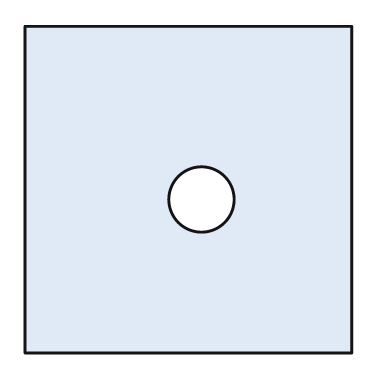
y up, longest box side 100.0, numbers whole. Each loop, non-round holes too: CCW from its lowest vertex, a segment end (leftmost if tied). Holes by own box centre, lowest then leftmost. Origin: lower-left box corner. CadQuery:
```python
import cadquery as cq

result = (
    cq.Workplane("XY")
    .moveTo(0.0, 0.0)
    .lineTo(100.0, 0.0)
    .lineTo(100.0, 100.0)
    .lineTo(0.0, 100.0)
    .close()
    .moveTo(54.0, 47.0)
    .circle(10.0)
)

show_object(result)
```